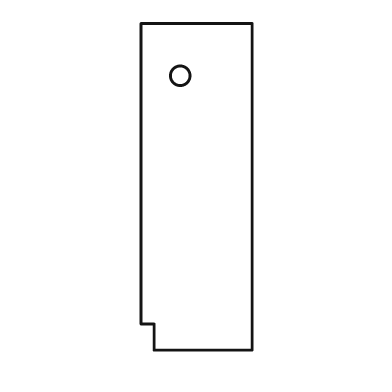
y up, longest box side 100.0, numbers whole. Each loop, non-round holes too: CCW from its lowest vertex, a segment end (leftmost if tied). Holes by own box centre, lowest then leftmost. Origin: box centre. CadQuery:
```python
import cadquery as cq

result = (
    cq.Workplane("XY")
    .moveTo(-13.0, -50.0)
    .lineTo(17.0, -50.0)
    .lineTo(17.0, 50.0)
    .lineTo(-17.0, 50.0)
    .lineTo(-17.0, -42.0)
    .lineTo(-13.0, -42.0)
    .close()
    .moveTo(-5.0, 34.0)
    .circle(3.0)
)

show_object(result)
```